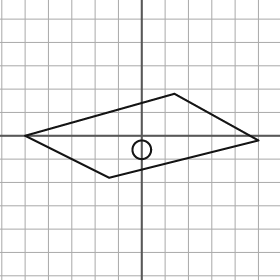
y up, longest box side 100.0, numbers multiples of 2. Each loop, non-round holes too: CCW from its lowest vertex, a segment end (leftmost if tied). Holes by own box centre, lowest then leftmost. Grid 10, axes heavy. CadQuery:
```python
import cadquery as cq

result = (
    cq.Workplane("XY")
    .moveTo(-14.0, -18.0)
    .lineTo(50.0, -2.0)
    .lineTo(14.0, 18.0)
    .lineTo(-50.0, 0.0)
    .close()
    .moveTo(0.0, -6.0)
    .circle(4.0)
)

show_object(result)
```